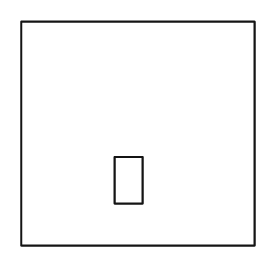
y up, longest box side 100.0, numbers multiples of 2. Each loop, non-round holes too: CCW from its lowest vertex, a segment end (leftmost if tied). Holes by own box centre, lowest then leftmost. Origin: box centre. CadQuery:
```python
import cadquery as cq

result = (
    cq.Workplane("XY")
    .moveTo(-50.0, -48.0)
    .lineTo(50.0, -48.0)
    .lineTo(50.0, 48.0)
    .lineTo(-50.0, 48.0)
    .close()
    .moveTo(-10.0, -30.0)
    .lineTo(2.0, -30.0)
    .lineTo(2.0, -10.0)
    .lineTo(-10.0, -10.0)
    .close()
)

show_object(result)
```